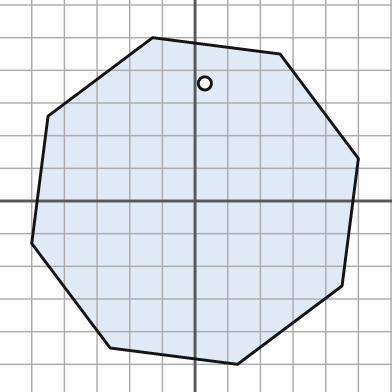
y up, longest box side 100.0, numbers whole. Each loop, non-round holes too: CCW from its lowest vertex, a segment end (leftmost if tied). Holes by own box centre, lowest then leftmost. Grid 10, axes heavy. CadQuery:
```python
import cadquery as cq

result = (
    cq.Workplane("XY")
    .moveTo(13.0, -50.0)
    .lineTo(45.0, -26.0)
    .lineTo(50.0, 13.0)
    .lineTo(26.0, 45.0)
    .lineTo(-13.0, 50.0)
    .lineTo(-45.0, 26.0)
    .lineTo(-50.0, -13.0)
    .lineTo(-26.0, -45.0)
    .close()
    .moveTo(3.0, 36.0)
    .circle(2.0)
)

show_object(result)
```